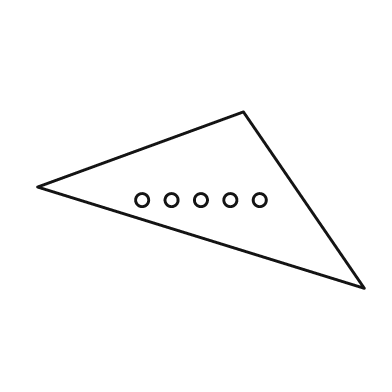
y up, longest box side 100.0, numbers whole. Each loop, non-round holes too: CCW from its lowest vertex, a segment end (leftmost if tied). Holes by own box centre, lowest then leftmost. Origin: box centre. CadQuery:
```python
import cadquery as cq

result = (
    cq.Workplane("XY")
    .moveTo(50.0, -27.0)
    .lineTo(13.0, 27.0)
    .lineTo(-50.0, 4.0)
    .close()
    .moveTo(-18.0, 0.0)
    .circle(2.0)
    .moveTo(-9.0, 0.0)
    .circle(2.0)
    .moveTo(0.0, 0.0)
    .circle(2.0)
    .moveTo(9.0, 0.0)
    .circle(2.0)
    .moveTo(18.0, 0.0)
    .circle(2.0)
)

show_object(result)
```